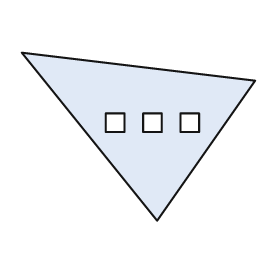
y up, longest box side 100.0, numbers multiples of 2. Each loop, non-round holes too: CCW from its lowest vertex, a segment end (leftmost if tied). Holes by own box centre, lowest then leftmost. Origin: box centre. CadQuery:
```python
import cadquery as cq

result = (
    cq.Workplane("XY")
    .moveTo(8.0, -36.0)
    .lineTo(50.0, 24.0)
    .lineTo(-50.0, 36.0)
    .close()
    .moveTo(-14.0, 2.0)
    .lineTo(-6.0, 2.0)
    .lineTo(-6.0, 10.0)
    .lineTo(-14.0, 10.0)
    .close()
    .moveTo(2.0, 2.0)
    .lineTo(10.0, 2.0)
    .lineTo(10.0, 10.0)
    .lineTo(2.0, 10.0)
    .close()
    .moveTo(18.0, 2.0)
    .lineTo(26.0, 2.0)
    .lineTo(26.0, 10.0)
    .lineTo(18.0, 10.0)
    .close()
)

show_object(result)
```